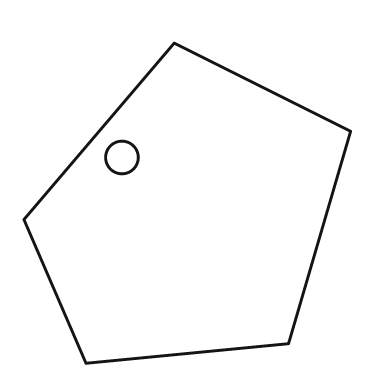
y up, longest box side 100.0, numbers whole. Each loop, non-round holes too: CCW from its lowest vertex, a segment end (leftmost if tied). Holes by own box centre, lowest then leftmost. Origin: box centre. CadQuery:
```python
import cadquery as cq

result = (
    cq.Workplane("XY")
    .moveTo(-31.0, -49.0)
    .lineTo(31.0, -43.0)
    .lineTo(50.0, 22.0)
    .lineTo(-4.0, 49.0)
    .lineTo(-50.0, -5.0)
    .close()
    .moveTo(-20.0, 14.0)
    .circle(5.0)
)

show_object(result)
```